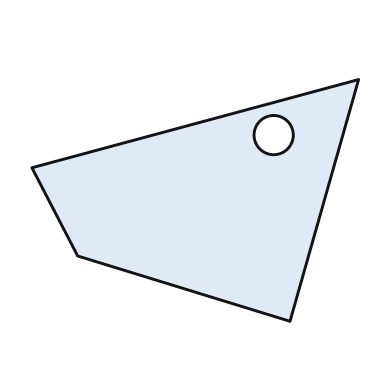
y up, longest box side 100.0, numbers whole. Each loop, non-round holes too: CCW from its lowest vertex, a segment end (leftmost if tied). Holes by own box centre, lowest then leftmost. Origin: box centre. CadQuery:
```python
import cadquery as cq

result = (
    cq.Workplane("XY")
    .moveTo(29.0, -37.0)
    .lineTo(50.0, 37.0)
    .lineTo(-50.0, 10.0)
    .lineTo(-36.0, -17.0)
    .close()
    .moveTo(24.0, 20.0)
    .circle(6.0)
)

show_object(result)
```